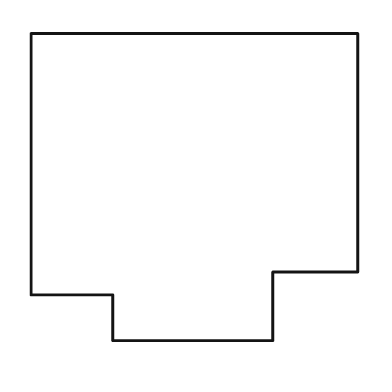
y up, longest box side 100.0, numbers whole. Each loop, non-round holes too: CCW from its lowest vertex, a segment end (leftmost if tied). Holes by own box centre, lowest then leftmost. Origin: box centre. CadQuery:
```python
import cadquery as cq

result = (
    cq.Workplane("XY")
    .moveTo(-25.0, -47.0)
    .lineTo(24.0, -47.0)
    .lineTo(24.0, -26.0)
    .lineTo(50.0, -26.0)
    .lineTo(50.0, 47.0)
    .lineTo(-50.0, 47.0)
    .lineTo(-50.0, -33.0)
    .lineTo(-25.0, -33.0)
    .close()
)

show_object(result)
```